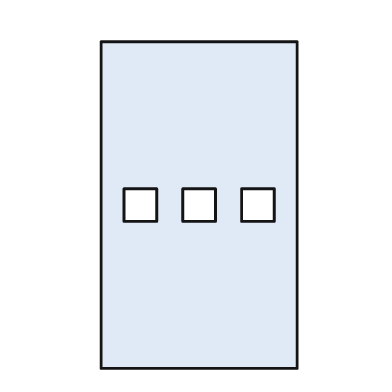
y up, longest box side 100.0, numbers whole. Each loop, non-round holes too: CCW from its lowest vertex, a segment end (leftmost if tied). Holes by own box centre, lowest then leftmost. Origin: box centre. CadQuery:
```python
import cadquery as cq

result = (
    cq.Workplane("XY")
    .moveTo(-30.0, -50.0)
    .lineTo(30.0, -50.0)
    .lineTo(30.0, 50.0)
    .lineTo(-30.0, 50.0)
    .close()
    .moveTo(-23.0, -5.0)
    .lineTo(-13.0, -5.0)
    .lineTo(-13.0, 5.0)
    .lineTo(-23.0, 5.0)
    .close()
    .moveTo(-5.0, -5.0)
    .lineTo(5.0, -5.0)
    .lineTo(5.0, 5.0)
    .lineTo(-5.0, 5.0)
    .close()
    .moveTo(13.0, -5.0)
    .lineTo(23.0, -5.0)
    .lineTo(23.0, 5.0)
    .lineTo(13.0, 5.0)
    .close()
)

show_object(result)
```